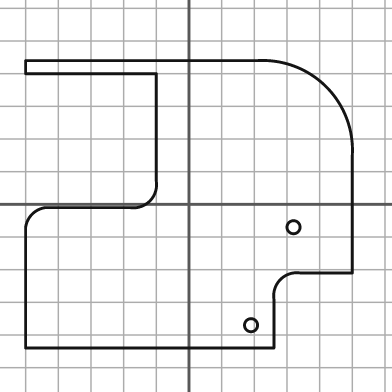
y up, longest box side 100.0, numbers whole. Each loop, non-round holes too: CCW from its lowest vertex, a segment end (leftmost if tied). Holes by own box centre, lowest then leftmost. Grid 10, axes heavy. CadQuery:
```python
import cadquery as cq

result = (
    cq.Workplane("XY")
    .moveTo(-50.0, -44.0)
    .lineTo(26.0, -44.0)
    .lineTo(26.0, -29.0)
    .threePointArc((28.0, -23.0), (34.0, -21.0))
    .lineTo(50.0, -21.0)
    .lineTo(50.0, 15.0)
    .threePointArc((42.0, 36.0), (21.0, 44.0))
    .lineTo(-50.0, 44.0)
    .lineTo(-50.0, 40.0)
    .lineTo(-10.0, 40.0)
    .lineTo(-10.0, 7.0)
    .threePointArc((-12.0, 1.0), (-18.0, -1.0))
    .lineTo(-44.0, -1.0)
    .threePointArc((-48.0, -3.0), (-50.0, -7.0))
    .close()
    .moveTo(19.0, -37.0)
    .circle(2.0)
    .moveTo(32.0, -7.0)
    .circle(2.0)
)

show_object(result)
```